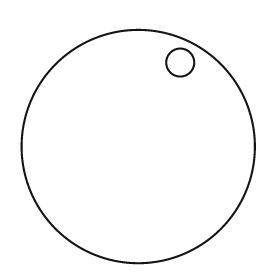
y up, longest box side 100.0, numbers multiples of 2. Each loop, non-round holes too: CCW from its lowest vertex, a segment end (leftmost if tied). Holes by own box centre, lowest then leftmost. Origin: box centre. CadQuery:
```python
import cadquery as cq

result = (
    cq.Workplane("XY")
    .moveTo(0.0, 0.0)
    .circle(50.0)
    .moveTo(18.0, 36.0)
    .circle(6.0)
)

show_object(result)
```